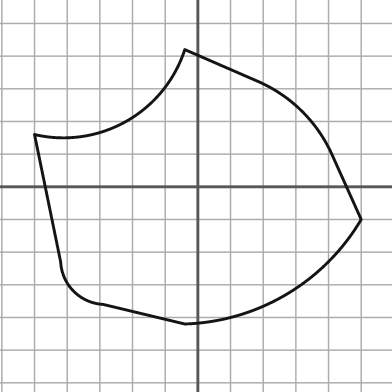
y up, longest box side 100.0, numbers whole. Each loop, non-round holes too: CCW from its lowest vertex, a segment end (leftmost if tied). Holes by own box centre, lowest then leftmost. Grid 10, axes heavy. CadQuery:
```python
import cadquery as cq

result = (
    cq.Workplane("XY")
    .moveTo(-4.0, -42.0)
    .threePointArc((27.0, -33.0), (50.0, -10.0))
    .lineTo(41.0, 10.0)
    .threePointArc((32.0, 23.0), (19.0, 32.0))
    .lineTo(-4.0, 42.0)
    .threePointArc((-22.0, 20.0), (-50.0, 16.0))
    .lineTo(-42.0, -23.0)
    .threePointArc((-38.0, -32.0), (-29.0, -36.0))
    .close()
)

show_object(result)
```